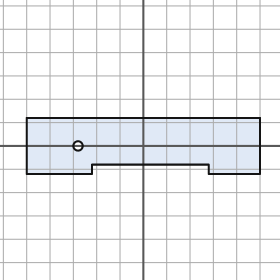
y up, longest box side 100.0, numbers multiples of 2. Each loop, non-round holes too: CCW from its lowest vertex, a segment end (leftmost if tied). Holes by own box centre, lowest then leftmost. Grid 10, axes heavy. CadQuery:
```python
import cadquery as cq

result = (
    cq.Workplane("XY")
    .moveTo(-50.0, -12.0)
    .lineTo(-22.0, -12.0)
    .lineTo(-22.0, -8.0)
    .lineTo(28.0, -8.0)
    .lineTo(28.0, -12.0)
    .lineTo(50.0, -12.0)
    .lineTo(50.0, 12.0)
    .lineTo(-50.0, 12.0)
    .close()
    .moveTo(-28.0, 0.0)
    .circle(2.0)
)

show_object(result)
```